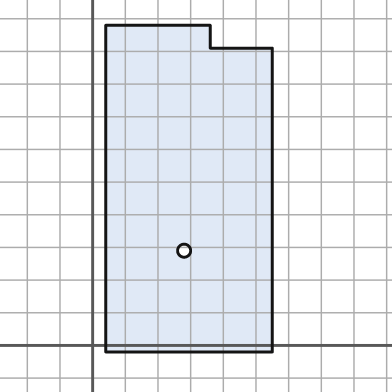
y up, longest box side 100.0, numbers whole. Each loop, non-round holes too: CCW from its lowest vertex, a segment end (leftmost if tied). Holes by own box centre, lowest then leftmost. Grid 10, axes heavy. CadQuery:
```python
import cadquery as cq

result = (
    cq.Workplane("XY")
    .moveTo(4.0, -2.0)
    .lineTo(55.0, -2.0)
    .lineTo(55.0, 91.0)
    .lineTo(36.0, 91.0)
    .lineTo(36.0, 98.0)
    .lineTo(4.0, 98.0)
    .close()
    .moveTo(28.0, 29.0)
    .circle(2.0)
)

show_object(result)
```